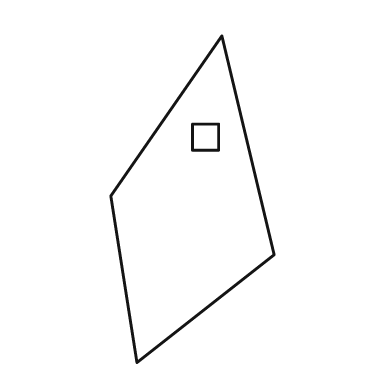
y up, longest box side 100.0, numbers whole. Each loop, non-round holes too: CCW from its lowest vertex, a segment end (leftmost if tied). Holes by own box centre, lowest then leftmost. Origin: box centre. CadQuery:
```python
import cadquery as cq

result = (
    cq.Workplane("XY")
    .moveTo(-17.0, -50.0)
    .lineTo(25.0, -17.0)
    .lineTo(9.0, 50.0)
    .lineTo(-25.0, 1.0)
    .close()
    .moveTo(0.0, 15.0)
    .lineTo(8.0, 15.0)
    .lineTo(8.0, 23.0)
    .lineTo(0.0, 23.0)
    .close()
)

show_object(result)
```